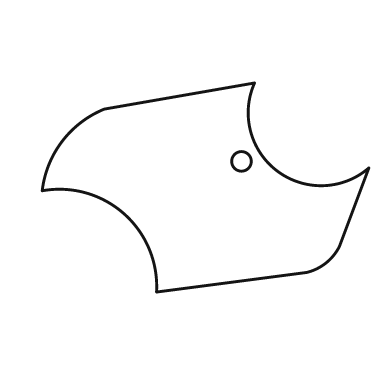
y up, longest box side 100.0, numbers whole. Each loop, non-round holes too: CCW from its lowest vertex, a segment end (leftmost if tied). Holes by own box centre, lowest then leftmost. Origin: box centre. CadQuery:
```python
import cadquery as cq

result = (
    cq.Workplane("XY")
    .moveTo(-15.0, -32.0)
    .lineTo(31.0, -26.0)
    .threePointArc((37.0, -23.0), (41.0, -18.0))
    .lineTo(50.0, 6.0)
    .threePointArc((22.0, 5.0), (15.0, 32.0))
    .lineTo(-31.0, 24.0)
    .threePointArc((-44.0, 14.0), (-50.0, -1.0))
    .threePointArc((-25.0, -8.0), (-15.0, -32.0))
    .close()
    .moveTo(11.0, 8.0)
    .circle(3.0)
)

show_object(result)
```